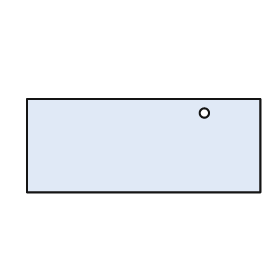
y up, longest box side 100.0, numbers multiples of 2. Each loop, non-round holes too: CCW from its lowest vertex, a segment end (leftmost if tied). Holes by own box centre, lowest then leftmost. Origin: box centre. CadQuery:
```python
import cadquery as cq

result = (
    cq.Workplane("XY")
    .moveTo(-50.0, -20.0)
    .lineTo(50.0, -20.0)
    .lineTo(50.0, 20.0)
    .lineTo(-50.0, 20.0)
    .close()
    .moveTo(26.0, 14.0)
    .circle(2.0)
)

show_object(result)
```